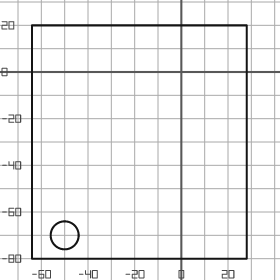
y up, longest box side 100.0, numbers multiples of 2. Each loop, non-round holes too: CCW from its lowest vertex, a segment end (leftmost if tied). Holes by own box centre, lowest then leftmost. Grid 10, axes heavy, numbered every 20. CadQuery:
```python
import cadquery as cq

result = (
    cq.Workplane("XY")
    .moveTo(-64.0, -80.0)
    .lineTo(28.0, -80.0)
    .lineTo(28.0, 20.0)
    .lineTo(-64.0, 20.0)
    .close()
    .moveTo(-50.0, -70.0)
    .circle(6.0)
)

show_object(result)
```